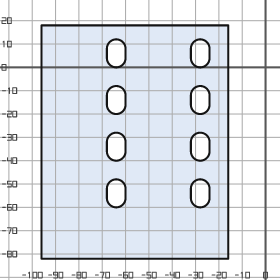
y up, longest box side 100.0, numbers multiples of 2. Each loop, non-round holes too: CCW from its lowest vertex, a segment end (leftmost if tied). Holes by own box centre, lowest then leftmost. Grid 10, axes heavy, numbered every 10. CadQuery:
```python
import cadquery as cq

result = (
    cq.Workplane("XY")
    .moveTo(-96.0, -82.0)
    .lineTo(-16.0, -82.0)
    .lineTo(-16.0, 18.0)
    .lineTo(-96.0, 18.0)
    .close()
    .moveTo(-68.0, -56.0)
    .threePointArc((-64.0, -60.0), (-60.0, -56.0))
    .lineTo(-60.0, -52.0)
    .threePointArc((-64.0, -48.0), (-68.0, -52.0))
    .close()
    .moveTo(-32.0, -56.0)
    .threePointArc((-28.0, -60.0), (-24.0, -56.0))
    .lineTo(-24.0, -52.0)
    .threePointArc((-28.0, -48.0), (-32.0, -52.0))
    .close()
    .moveTo(-68.0, -36.0)
    .threePointArc((-64.0, -40.0), (-60.0, -36.0))
    .lineTo(-60.0, -32.0)
    .threePointArc((-64.0, -28.0), (-68.0, -32.0))
    .close()
    .moveTo(-32.0, -36.0)
    .threePointArc((-28.0, -40.0), (-24.0, -36.0))
    .lineTo(-24.0, -32.0)
    .threePointArc((-28.0, -28.0), (-32.0, -32.0))
    .close()
    .moveTo(-68.0, -16.0)
    .threePointArc((-64.0, -20.0), (-60.0, -16.0))
    .lineTo(-60.0, -12.0)
    .threePointArc((-64.0, -8.0), (-68.0, -12.0))
    .close()
    .moveTo(-32.0, -16.0)
    .threePointArc((-28.0, -20.0), (-24.0, -16.0))
    .lineTo(-24.0, -12.0)
    .threePointArc((-28.0, -8.0), (-32.0, -12.0))
    .close()
    .moveTo(-68.0, 4.0)
    .threePointArc((-64.0, 0.0), (-60.0, 4.0))
    .lineTo(-60.0, 8.0)
    .threePointArc((-64.0, 12.0), (-68.0, 8.0))
    .close()
    .moveTo(-32.0, 4.0)
    .threePointArc((-28.0, 0.0), (-24.0, 4.0))
    .lineTo(-24.0, 8.0)
    .threePointArc((-28.0, 12.0), (-32.0, 8.0))
    .close()
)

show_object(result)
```